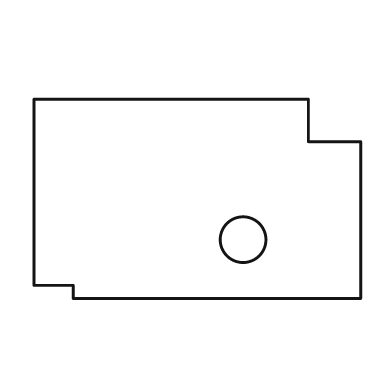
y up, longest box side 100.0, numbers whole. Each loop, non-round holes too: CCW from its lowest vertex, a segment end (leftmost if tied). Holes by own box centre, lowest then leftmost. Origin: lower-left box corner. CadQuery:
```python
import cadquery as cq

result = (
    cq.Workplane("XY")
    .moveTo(12.0, 0.0)
    .lineTo(100.0, 0.0)
    .lineTo(100.0, 48.0)
    .lineTo(84.0, 48.0)
    .lineTo(84.0, 61.0)
    .lineTo(0.0, 61.0)
    .lineTo(0.0, 4.0)
    .lineTo(12.0, 4.0)
    .close()
    .moveTo(64.0, 18.0)
    .circle(7.0)
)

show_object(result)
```